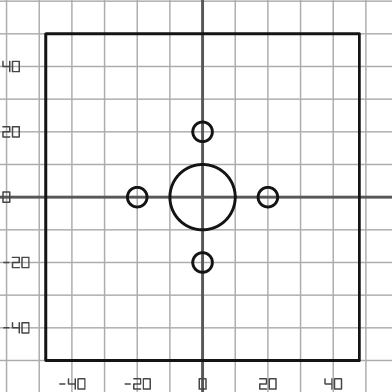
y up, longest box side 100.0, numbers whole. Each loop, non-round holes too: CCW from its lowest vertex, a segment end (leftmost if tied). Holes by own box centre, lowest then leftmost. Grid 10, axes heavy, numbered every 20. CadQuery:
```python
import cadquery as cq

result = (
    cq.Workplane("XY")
    .moveTo(-48.0, -50.0)
    .lineTo(48.0, -50.0)
    .lineTo(48.0, 50.0)
    .lineTo(-48.0, 50.0)
    .close()
    .moveTo(0.0, -20.0)
    .circle(3.0)
    .moveTo(-20.0, 0.0)
    .circle(3.0)
    .moveTo(0.0, 0.0)
    .circle(10.0)
    .moveTo(20.0, 0.0)
    .circle(3.0)
    .moveTo(0.0, 20.0)
    .circle(3.0)
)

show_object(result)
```